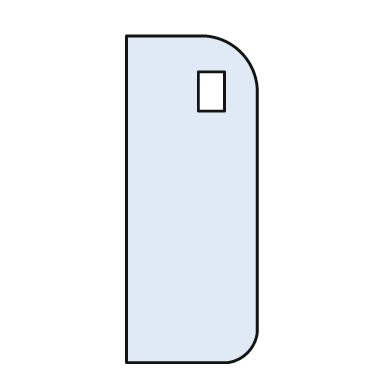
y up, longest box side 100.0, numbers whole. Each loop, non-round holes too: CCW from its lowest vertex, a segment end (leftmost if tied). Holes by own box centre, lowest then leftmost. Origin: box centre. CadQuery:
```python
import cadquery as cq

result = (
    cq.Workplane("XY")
    .moveTo(-20.0, -50.0)
    .lineTo(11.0, -50.0)
    .threePointArc((17.0, -47.0), (20.0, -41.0))
    .lineTo(20.0, 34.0)
    .threePointArc((15.0, 45.0), (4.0, 50.0))
    .lineTo(-20.0, 50.0)
    .close()
    .moveTo(2.0, 27.0)
    .lineTo(10.0, 27.0)
    .lineTo(10.0, 39.0)
    .lineTo(2.0, 39.0)
    .close()
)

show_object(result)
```